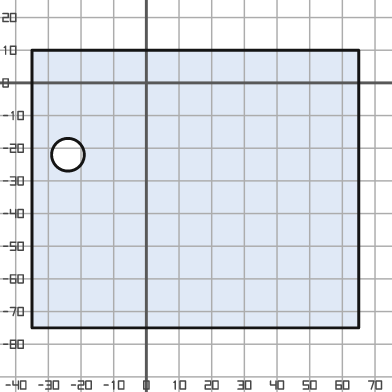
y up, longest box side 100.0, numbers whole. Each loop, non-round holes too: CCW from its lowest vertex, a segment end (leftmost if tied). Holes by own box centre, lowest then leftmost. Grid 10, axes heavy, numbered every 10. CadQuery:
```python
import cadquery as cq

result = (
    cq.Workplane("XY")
    .moveTo(-35.0, -75.0)
    .lineTo(65.0, -75.0)
    .lineTo(65.0, 10.0)
    .lineTo(-35.0, 10.0)
    .close()
    .moveTo(-24.0, -22.0)
    .circle(5.0)
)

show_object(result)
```